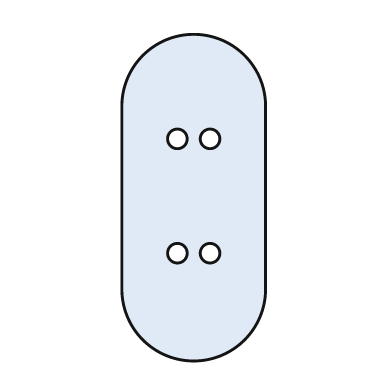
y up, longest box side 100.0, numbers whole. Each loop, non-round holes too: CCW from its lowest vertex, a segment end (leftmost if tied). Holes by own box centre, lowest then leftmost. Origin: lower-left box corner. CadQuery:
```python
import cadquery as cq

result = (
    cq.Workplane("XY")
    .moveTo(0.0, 22.0)
    .threePointArc((22.0, 0.0), (44.0, 22.0))
    .lineTo(44.0, 78.0)
    .threePointArc((22.0, 100.0), (0.0, 78.0))
    .close()
    .moveTo(17.0, 33.0)
    .circle(3.0)
    .moveTo(27.0, 33.0)
    .circle(3.0)
    .moveTo(17.0, 68.0)
    .circle(3.0)
    .moveTo(27.0, 68.0)
    .circle(3.0)
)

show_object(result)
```